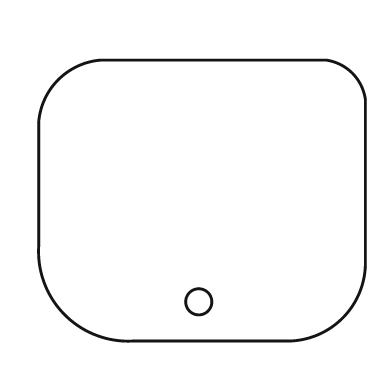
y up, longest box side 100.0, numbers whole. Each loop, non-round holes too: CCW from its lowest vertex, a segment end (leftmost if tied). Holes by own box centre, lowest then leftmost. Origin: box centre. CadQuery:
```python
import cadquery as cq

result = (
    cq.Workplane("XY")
    .moveTo(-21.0, -43.0)
    .lineTo(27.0, -43.0)
    .threePointArc((43.0, -36.0), (50.0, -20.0))
    .lineTo(50.0, 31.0)
    .threePointArc((46.0, 39.0), (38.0, 43.0))
    .lineTo(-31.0, 43.0)
    .threePointArc((-44.0, 37.0), (-50.0, 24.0))
    .lineTo(-50.0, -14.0)
    .threePointArc((-42.0, -35.0), (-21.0, -43.0))
    .close()
    .moveTo(-1.0, -31.0)
    .circle(4.0)
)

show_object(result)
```